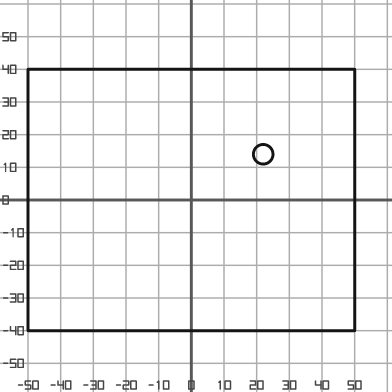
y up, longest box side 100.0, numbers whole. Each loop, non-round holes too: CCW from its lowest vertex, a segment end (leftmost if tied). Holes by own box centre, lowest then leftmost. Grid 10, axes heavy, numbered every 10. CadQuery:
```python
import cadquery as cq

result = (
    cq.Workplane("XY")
    .moveTo(-50.0, -40.0)
    .lineTo(50.0, -40.0)
    .lineTo(50.0, 40.0)
    .lineTo(-50.0, 40.0)
    .close()
    .moveTo(22.0, 14.0)
    .circle(3.0)
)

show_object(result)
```